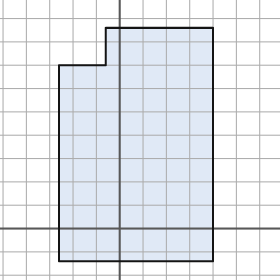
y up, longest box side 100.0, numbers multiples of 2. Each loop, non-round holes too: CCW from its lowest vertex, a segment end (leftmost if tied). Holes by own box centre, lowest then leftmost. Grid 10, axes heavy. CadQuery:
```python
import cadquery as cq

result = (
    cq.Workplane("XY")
    .moveTo(-26.0, -14.0)
    .lineTo(40.0, -14.0)
    .lineTo(40.0, 86.0)
    .lineTo(-6.0, 86.0)
    .lineTo(-6.0, 70.0)
    .lineTo(-26.0, 70.0)
    .close()
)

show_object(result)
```